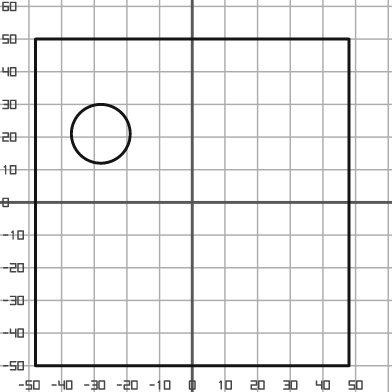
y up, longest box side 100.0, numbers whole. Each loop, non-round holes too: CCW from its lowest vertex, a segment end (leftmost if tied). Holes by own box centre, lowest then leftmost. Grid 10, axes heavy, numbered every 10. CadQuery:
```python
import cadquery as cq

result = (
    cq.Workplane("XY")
    .moveTo(-48.0, -50.0)
    .lineTo(48.0, -50.0)
    .lineTo(48.0, 50.0)
    .lineTo(-48.0, 50.0)
    .close()
    .moveTo(-28.0, 21.0)
    .circle(9.0)
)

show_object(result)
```